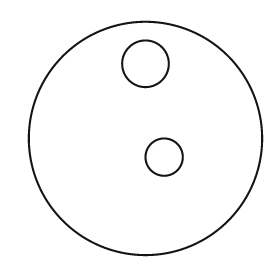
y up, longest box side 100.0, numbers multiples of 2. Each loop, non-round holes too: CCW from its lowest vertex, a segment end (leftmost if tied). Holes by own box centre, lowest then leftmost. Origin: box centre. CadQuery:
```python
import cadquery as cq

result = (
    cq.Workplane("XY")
    .moveTo(0.0, 0.0)
    .circle(50.0)
    .moveTo(8.0, -8.0)
    .circle(8.0)
    .moveTo(0.0, 32.0)
    .circle(10.0)
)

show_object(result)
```